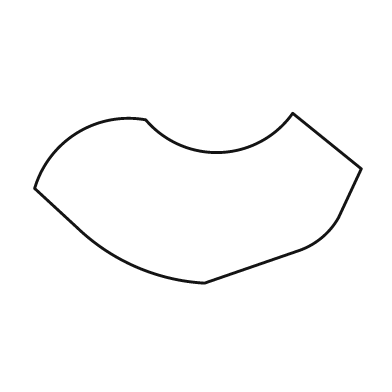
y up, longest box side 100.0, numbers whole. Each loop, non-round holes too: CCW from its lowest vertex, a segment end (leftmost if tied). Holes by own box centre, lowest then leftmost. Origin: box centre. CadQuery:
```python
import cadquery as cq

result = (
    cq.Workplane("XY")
    .moveTo(2.0, -26.0)
    .lineTo(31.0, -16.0)
    .threePointArc((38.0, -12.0), (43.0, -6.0))
    .lineTo(50.0, 9.0)
    .lineTo(29.0, 26.0)
    .threePointArc((7.0, 14.0), (-16.0, 24.0))
    .threePointArc((-37.0, 20.0), (-50.0, 3.0))
    .lineTo(-37.0, -9.0)
    .threePointArc((-19.0, -21.0), (2.0, -26.0))
    .close()
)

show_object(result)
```